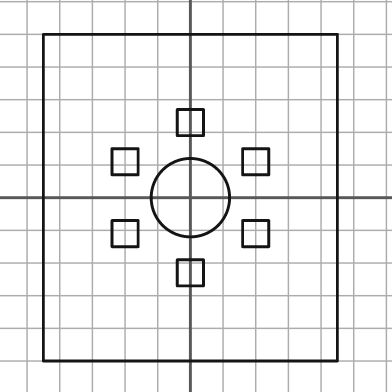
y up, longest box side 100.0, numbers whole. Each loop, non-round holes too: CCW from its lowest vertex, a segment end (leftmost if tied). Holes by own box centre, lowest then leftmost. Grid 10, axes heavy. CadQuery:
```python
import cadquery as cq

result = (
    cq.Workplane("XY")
    .moveTo(-45.0, -50.0)
    .lineTo(45.0, -50.0)
    .lineTo(45.0, 50.0)
    .lineTo(-45.0, 50.0)
    .close()
    .moveTo(-4.0, -27.0)
    .lineTo(4.0, -27.0)
    .lineTo(4.0, -19.0)
    .lineTo(-4.0, -19.0)
    .close()
    .moveTo(-24.0, -15.0)
    .lineTo(-16.0, -15.0)
    .lineTo(-16.0, -7.0)
    .lineTo(-24.0, -7.0)
    .close()
    .moveTo(16.0, -15.0)
    .lineTo(24.0, -15.0)
    .lineTo(24.0, -7.0)
    .lineTo(16.0, -7.0)
    .close()
    .moveTo(0.0, 0.0)
    .circle(12.0)
    .moveTo(-24.0, 7.0)
    .lineTo(-16.0, 7.0)
    .lineTo(-16.0, 15.0)
    .lineTo(-24.0, 15.0)
    .close()
    .moveTo(16.0, 7.0)
    .lineTo(24.0, 7.0)
    .lineTo(24.0, 15.0)
    .lineTo(16.0, 15.0)
    .close()
    .moveTo(-4.0, 19.0)
    .lineTo(4.0, 19.0)
    .lineTo(4.0, 27.0)
    .lineTo(-4.0, 27.0)
    .close()
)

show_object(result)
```